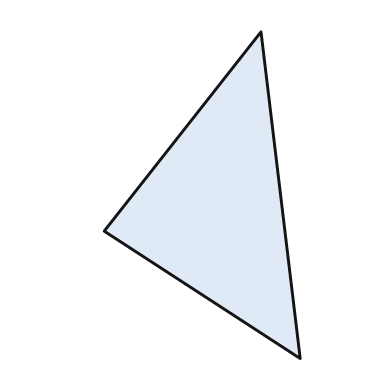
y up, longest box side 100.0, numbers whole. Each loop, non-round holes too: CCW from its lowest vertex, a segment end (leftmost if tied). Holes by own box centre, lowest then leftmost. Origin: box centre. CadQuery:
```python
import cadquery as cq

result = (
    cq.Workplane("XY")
    .moveTo(30.0, -50.0)
    .lineTo(18.0, 50.0)
    .lineTo(-30.0, -11.0)
    .close()
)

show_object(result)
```